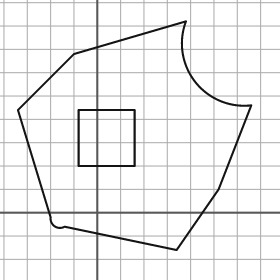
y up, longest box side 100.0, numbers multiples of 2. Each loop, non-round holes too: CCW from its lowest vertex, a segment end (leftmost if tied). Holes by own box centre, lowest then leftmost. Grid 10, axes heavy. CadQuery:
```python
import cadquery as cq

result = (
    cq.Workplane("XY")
    .moveTo(34.0, -16.0)
    .lineTo(52.0, 10.0)
    .lineTo(66.0, 46.0)
    .threePointArc((42.0, 56.0), (38.0, 82.0))
    .lineTo(-10.0, 68.0)
    .lineTo(-34.0, 44.0)
    .lineTo(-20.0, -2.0)
    .threePointArc((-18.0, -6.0), (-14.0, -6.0))
    .close()
    .moveTo(-8.0, 20.0)
    .lineTo(16.0, 20.0)
    .lineTo(16.0, 44.0)
    .lineTo(-8.0, 44.0)
    .close()
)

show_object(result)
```